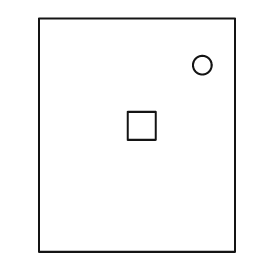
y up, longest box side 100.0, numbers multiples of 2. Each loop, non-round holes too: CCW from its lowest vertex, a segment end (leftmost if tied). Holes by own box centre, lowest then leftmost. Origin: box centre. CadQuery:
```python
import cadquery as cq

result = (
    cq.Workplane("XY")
    .moveTo(-42.0, -50.0)
    .lineTo(42.0, -50.0)
    .lineTo(42.0, 50.0)
    .lineTo(-42.0, 50.0)
    .close()
    .moveTo(-4.0, -2.0)
    .lineTo(8.0, -2.0)
    .lineTo(8.0, 10.0)
    .lineTo(-4.0, 10.0)
    .close()
    .moveTo(28.0, 30.0)
    .circle(4.0)
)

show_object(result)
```